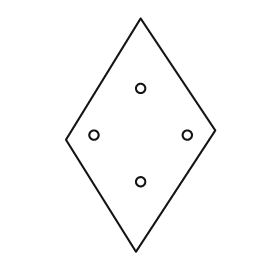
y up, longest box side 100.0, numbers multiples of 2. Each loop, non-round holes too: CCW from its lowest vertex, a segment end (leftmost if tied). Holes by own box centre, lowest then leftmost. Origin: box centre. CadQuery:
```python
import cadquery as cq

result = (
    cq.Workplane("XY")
    .moveTo(-2.0, -50.0)
    .lineTo(32.0, 2.0)
    .lineTo(0.0, 50.0)
    .lineTo(-32.0, -2.0)
    .close()
    .moveTo(0.0, -20.0)
    .circle(2.0)
    .moveTo(-20.0, 0.0)
    .circle(2.0)
    .moveTo(20.0, 0.0)
    .circle(2.0)
    .moveTo(0.0, 20.0)
    .circle(2.0)
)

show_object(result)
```